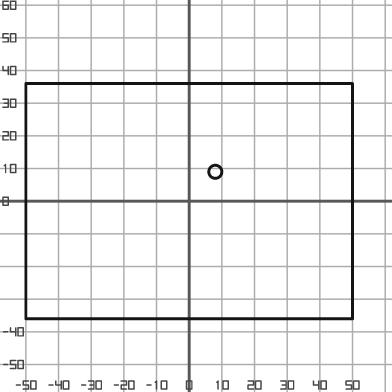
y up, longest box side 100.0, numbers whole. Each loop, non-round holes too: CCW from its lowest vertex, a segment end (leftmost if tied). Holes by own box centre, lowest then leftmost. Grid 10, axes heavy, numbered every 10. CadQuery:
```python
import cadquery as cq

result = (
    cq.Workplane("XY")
    .moveTo(-50.0, -36.0)
    .lineTo(50.0, -36.0)
    .lineTo(50.0, 36.0)
    .lineTo(-50.0, 36.0)
    .close()
    .moveTo(8.0, 9.0)
    .circle(2.0)
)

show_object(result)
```